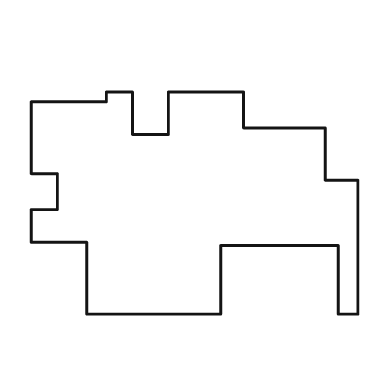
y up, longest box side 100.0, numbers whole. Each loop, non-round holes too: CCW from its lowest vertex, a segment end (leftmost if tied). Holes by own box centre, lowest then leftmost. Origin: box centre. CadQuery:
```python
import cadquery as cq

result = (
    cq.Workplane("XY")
    .moveTo(-33.0, -34.0)
    .lineTo(8.0, -34.0)
    .lineTo(8.0, -13.0)
    .lineTo(44.0, -13.0)
    .lineTo(44.0, -34.0)
    .lineTo(50.0, -34.0)
    .lineTo(50.0, 7.0)
    .lineTo(40.0, 7.0)
    .lineTo(40.0, 23.0)
    .lineTo(15.0, 23.0)
    .lineTo(15.0, 34.0)
    .lineTo(-8.0, 34.0)
    .lineTo(-8.0, 21.0)
    .lineTo(-19.0, 21.0)
    .lineTo(-19.0, 34.0)
    .lineTo(-27.0, 34.0)
    .lineTo(-27.0, 31.0)
    .lineTo(-50.0, 31.0)
    .lineTo(-50.0, 9.0)
    .lineTo(-42.0, 9.0)
    .lineTo(-42.0, -2.0)
    .lineTo(-50.0, -2.0)
    .lineTo(-50.0, -12.0)
    .lineTo(-33.0, -12.0)
    .close()
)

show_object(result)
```